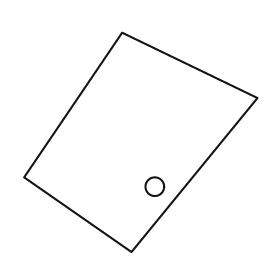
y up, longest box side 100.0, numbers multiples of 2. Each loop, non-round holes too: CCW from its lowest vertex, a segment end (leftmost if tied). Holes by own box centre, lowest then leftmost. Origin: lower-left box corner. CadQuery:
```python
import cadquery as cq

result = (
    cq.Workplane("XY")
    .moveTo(46.0, 0.0)
    .lineTo(100.0, 66.0)
    .lineTo(42.0, 94.0)
    .lineTo(0.0, 32.0)
    .close()
    .moveTo(56.0, 28.0)
    .circle(4.0)
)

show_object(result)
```